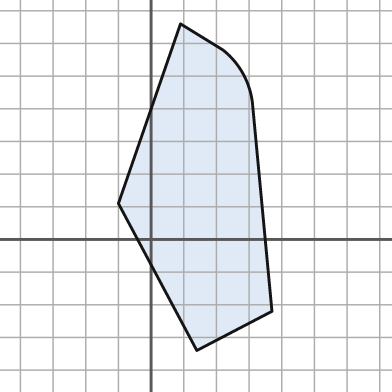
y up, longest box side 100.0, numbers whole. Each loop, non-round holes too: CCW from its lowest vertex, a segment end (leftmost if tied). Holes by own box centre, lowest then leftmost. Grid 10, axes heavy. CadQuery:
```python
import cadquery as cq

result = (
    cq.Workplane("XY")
    .moveTo(14.0, -34.0)
    .lineTo(37.0, -22.0)
    .lineTo(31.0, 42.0)
    .threePointArc((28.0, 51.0), (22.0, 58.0))
    .lineTo(9.0, 66.0)
    .lineTo(-10.0, 11.0)
    .close()
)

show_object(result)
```